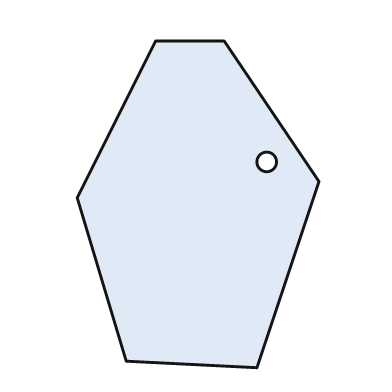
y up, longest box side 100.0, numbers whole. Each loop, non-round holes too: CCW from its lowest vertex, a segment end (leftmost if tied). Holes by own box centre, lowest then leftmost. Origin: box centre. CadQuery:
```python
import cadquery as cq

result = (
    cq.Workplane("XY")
    .moveTo(18.0, -50.0)
    .lineTo(37.0, 7.0)
    .lineTo(8.0, 50.0)
    .lineTo(-13.0, 50.0)
    .lineTo(-37.0, 2.0)
    .lineTo(-22.0, -48.0)
    .close()
    .moveTo(21.0, 13.0)
    .circle(3.0)
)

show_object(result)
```